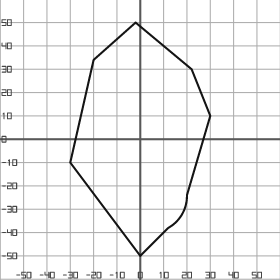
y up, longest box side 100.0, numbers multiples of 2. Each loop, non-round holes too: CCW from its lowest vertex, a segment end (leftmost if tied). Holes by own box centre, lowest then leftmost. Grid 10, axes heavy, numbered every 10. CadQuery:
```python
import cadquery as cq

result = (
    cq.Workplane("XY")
    .moveTo(0.0, -50.0)
    .lineTo(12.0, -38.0)
    .threePointArc((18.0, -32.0), (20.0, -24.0))
    .lineTo(30.0, 10.0)
    .lineTo(22.0, 30.0)
    .lineTo(-2.0, 50.0)
    .lineTo(-20.0, 34.0)
    .lineTo(-30.0, -10.0)
    .close()
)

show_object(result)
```